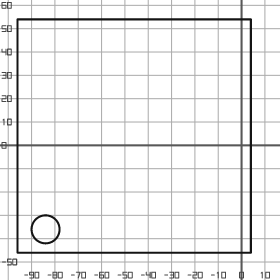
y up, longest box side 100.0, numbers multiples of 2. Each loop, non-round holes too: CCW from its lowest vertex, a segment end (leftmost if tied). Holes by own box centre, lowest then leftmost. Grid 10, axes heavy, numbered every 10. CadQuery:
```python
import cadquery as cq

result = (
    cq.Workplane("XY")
    .moveTo(-96.0, -46.0)
    .lineTo(4.0, -46.0)
    .lineTo(4.0, 54.0)
    .lineTo(-96.0, 54.0)
    .close()
    .moveTo(-84.0, -36.0)
    .circle(6.0)
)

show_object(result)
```